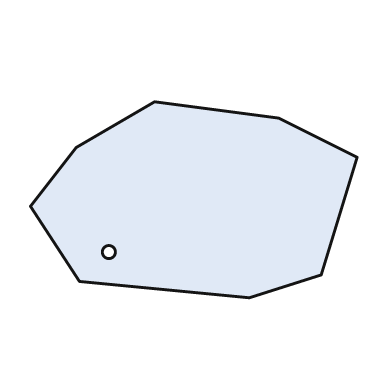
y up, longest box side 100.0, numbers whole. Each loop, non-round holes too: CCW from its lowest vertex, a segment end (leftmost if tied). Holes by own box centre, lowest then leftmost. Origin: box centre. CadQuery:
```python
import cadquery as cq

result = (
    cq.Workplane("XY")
    .moveTo(17.0, -30.0)
    .lineTo(39.0, -23.0)
    .lineTo(50.0, 13.0)
    .lineTo(26.0, 25.0)
    .lineTo(-12.0, 30.0)
    .lineTo(-36.0, 16.0)
    .lineTo(-50.0, -2.0)
    .lineTo(-35.0, -25.0)
    .close()
    .moveTo(-26.0, -16.0)
    .circle(2.0)
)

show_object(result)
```